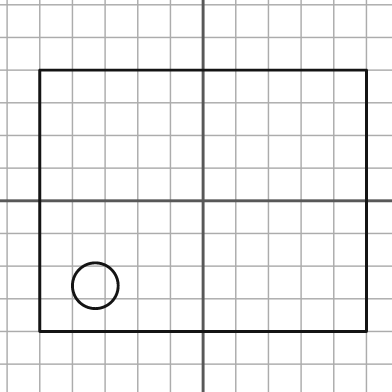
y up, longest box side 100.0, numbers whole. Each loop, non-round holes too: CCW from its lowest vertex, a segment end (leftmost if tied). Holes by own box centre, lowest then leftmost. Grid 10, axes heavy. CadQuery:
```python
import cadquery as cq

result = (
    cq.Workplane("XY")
    .moveTo(-50.0, -40.0)
    .lineTo(50.0, -40.0)
    .lineTo(50.0, 40.0)
    .lineTo(-50.0, 40.0)
    .close()
    .moveTo(-33.0, -26.0)
    .circle(7.0)
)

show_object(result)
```